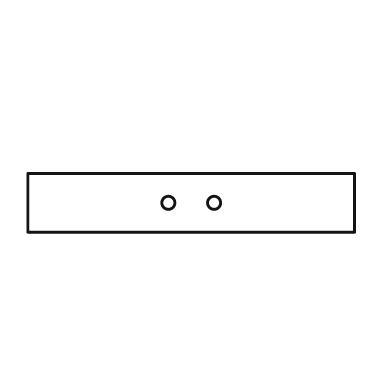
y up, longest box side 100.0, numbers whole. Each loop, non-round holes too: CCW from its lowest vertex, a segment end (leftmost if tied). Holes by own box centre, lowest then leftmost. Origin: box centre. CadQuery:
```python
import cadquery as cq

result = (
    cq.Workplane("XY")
    .moveTo(-50.0, -9.0)
    .lineTo(50.0, -9.0)
    .lineTo(50.0, 9.0)
    .lineTo(-50.0, 9.0)
    .close()
    .moveTo(-7.0, 0.0)
    .circle(2.0)
    .moveTo(7.0, 0.0)
    .circle(2.0)
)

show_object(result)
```